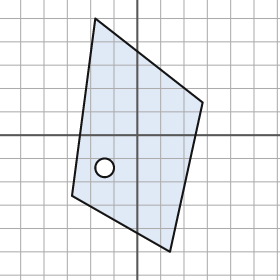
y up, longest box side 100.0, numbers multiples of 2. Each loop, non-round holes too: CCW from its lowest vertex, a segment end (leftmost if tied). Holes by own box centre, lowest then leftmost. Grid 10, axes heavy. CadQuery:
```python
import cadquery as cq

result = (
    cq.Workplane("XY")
    .moveTo(14.0, -50.0)
    .lineTo(28.0, 14.0)
    .lineTo(-18.0, 50.0)
    .lineTo(-28.0, -26.0)
    .close()
    .moveTo(-14.0, -14.0)
    .circle(4.0)
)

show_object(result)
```